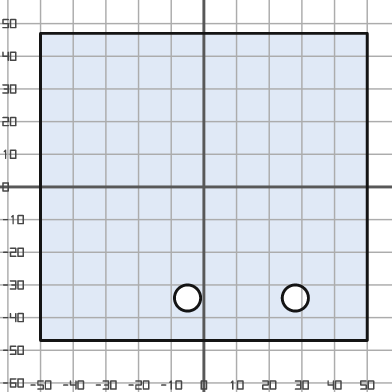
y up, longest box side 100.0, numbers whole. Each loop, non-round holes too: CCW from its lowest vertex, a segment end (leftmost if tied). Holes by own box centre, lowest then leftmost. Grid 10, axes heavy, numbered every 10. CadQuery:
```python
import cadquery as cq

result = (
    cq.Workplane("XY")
    .moveTo(-50.0, -47.0)
    .lineTo(50.0, -47.0)
    .lineTo(50.0, 47.0)
    .lineTo(-50.0, 47.0)
    .close()
    .moveTo(-5.0, -34.0)
    .circle(4.0)
    .moveTo(28.0, -34.0)
    .circle(4.0)
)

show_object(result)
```